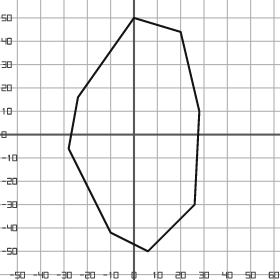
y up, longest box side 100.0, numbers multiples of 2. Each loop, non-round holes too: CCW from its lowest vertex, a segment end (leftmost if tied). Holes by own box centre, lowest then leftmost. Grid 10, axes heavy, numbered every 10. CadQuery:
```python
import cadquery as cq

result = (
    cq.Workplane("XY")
    .moveTo(6.0, -50.0)
    .lineTo(26.0, -30.0)
    .lineTo(28.0, 10.0)
    .lineTo(20.0, 44.0)
    .lineTo(0.0, 50.0)
    .lineTo(-24.0, 16.0)
    .lineTo(-28.0, -6.0)
    .lineTo(-10.0, -42.0)
    .close()
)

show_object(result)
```